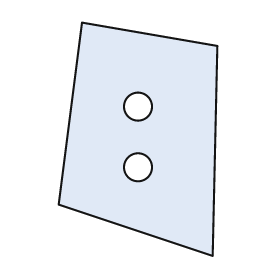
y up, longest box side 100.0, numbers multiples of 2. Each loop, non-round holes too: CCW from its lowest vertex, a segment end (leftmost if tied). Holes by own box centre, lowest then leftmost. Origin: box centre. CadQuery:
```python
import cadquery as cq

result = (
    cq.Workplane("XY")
    .moveTo(32.0, -50.0)
    .lineTo(34.0, 40.0)
    .lineTo(-24.0, 50.0)
    .lineTo(-34.0, -28.0)
    .close()
    .moveTo(0.0, -12.0)
    .circle(6.0)
    .moveTo(0.0, 14.0)
    .circle(6.0)
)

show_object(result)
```